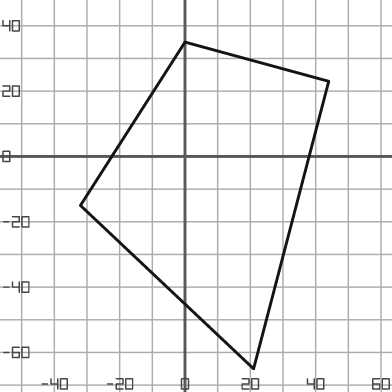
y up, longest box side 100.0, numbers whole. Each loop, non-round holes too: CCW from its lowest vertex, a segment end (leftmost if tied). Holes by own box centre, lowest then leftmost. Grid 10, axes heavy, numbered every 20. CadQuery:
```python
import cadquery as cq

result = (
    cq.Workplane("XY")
    .moveTo(21.0, -65.0)
    .lineTo(44.0, 23.0)
    .lineTo(0.0, 35.0)
    .lineTo(-32.0, -15.0)
    .close()
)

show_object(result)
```